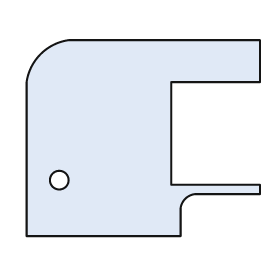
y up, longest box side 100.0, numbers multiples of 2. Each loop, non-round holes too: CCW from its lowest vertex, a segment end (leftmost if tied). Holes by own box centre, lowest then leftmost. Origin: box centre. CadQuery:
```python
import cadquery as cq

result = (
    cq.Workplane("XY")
    .moveTo(-50.0, -42.0)
    .lineTo(16.0, -42.0)
    .lineTo(16.0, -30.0)
    .threePointArc((18.0, -26.0), (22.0, -24.0))
    .lineTo(50.0, -24.0)
    .lineTo(50.0, -20.0)
    .lineTo(12.0, -20.0)
    .lineTo(12.0, 24.0)
    .lineTo(50.0, 24.0)
    .lineTo(50.0, 42.0)
    .lineTo(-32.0, 42.0)
    .threePointArc((-44.0, 36.0), (-50.0, 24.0))
    .close()
    .moveTo(-36.0, -18.0)
    .circle(4.0)
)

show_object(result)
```